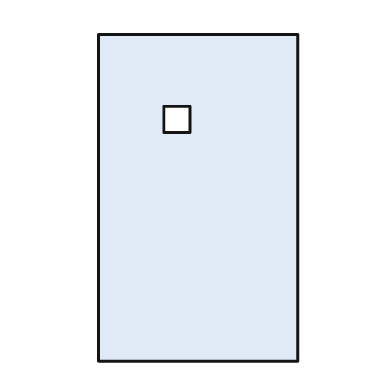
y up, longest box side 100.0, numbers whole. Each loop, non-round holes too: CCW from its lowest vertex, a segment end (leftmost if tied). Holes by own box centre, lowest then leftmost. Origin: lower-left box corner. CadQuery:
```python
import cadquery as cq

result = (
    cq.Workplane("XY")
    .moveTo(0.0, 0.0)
    .lineTo(61.0, 0.0)
    .lineTo(61.0, 100.0)
    .lineTo(0.0, 100.0)
    .close()
    .moveTo(20.0, 70.0)
    .lineTo(28.0, 70.0)
    .lineTo(28.0, 78.0)
    .lineTo(20.0, 78.0)
    .close()
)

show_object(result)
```